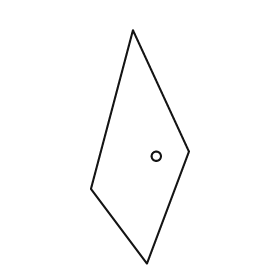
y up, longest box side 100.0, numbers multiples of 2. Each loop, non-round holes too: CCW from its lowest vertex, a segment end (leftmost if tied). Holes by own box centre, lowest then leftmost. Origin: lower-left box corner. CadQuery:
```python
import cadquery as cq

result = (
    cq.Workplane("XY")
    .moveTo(24.0, 0.0)
    .lineTo(42.0, 48.0)
    .lineTo(18.0, 100.0)
    .lineTo(0.0, 32.0)
    .close()
    .moveTo(28.0, 46.0)
    .circle(2.0)
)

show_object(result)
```